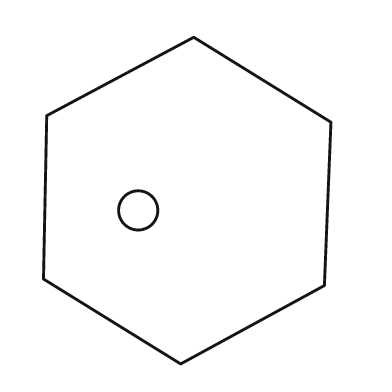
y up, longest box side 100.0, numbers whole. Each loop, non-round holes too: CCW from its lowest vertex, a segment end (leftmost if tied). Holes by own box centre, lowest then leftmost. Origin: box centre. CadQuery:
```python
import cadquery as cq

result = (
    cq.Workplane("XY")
    .moveTo(-2.0, -50.0)
    .lineTo(42.0, -26.0)
    .lineTo(44.0, 24.0)
    .lineTo(2.0, 50.0)
    .lineTo(-43.0, 26.0)
    .lineTo(-44.0, -24.0)
    .close()
    .moveTo(-15.0, -3.0)
    .circle(6.0)
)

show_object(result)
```